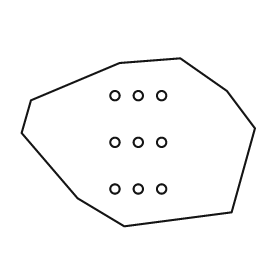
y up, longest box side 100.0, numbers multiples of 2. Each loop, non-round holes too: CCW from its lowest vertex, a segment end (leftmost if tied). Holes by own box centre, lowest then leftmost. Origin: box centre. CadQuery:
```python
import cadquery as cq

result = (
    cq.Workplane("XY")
    .moveTo(-6.0, -36.0)
    .lineTo(40.0, -30.0)
    .lineTo(50.0, 6.0)
    .lineTo(38.0, 22.0)
    .lineTo(18.0, 36.0)
    .lineTo(-8.0, 34.0)
    .lineTo(-46.0, 18.0)
    .lineTo(-50.0, 4.0)
    .lineTo(-26.0, -24.0)
    .close()
    .moveTo(-10.0, -20.0)
    .circle(2.0)
    .moveTo(0.0, -20.0)
    .circle(2.0)
    .moveTo(10.0, -20.0)
    .circle(2.0)
    .moveTo(-10.0, 0.0)
    .circle(2.0)
    .moveTo(0.0, 0.0)
    .circle(2.0)
    .moveTo(10.0, 0.0)
    .circle(2.0)
    .moveTo(-10.0, 20.0)
    .circle(2.0)
    .moveTo(0.0, 20.0)
    .circle(2.0)
    .moveTo(10.0, 20.0)
    .circle(2.0)
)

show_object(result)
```